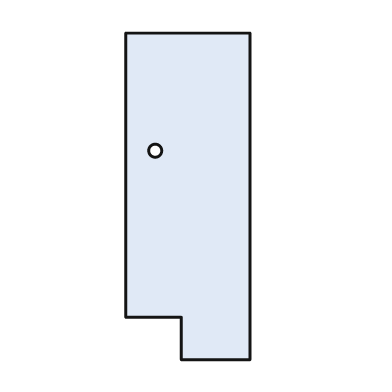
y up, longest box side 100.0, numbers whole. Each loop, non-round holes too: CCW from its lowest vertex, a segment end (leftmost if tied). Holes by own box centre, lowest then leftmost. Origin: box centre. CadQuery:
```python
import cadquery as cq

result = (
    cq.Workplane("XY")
    .moveTo(-2.0, -50.0)
    .lineTo(19.0, -50.0)
    .lineTo(19.0, 50.0)
    .lineTo(-19.0, 50.0)
    .lineTo(-19.0, -37.0)
    .lineTo(-2.0, -37.0)
    .close()
    .moveTo(-10.0, 14.0)
    .circle(2.0)
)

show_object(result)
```